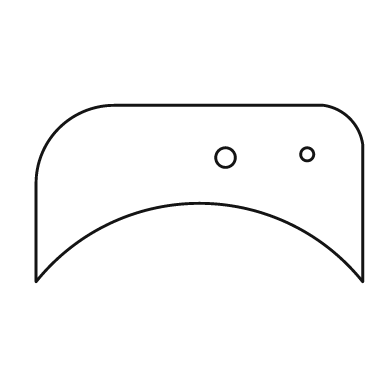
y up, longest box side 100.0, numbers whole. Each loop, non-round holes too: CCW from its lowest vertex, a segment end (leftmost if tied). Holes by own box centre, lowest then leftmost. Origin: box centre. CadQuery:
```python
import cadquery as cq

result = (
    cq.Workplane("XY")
    .moveTo(-50.0, -27.0)
    .threePointArc((0.0, -3.0), (50.0, -27.0))
    .lineTo(50.0, 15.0)
    .threePointArc((46.0, 23.0), (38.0, 27.0))
    .lineTo(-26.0, 27.0)
    .threePointArc((-43.0, 20.0), (-50.0, 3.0))
    .close()
    .moveTo(8.0, 11.0)
    .circle(3.0)
    .moveTo(33.0, 12.0)
    .circle(2.0)
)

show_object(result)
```